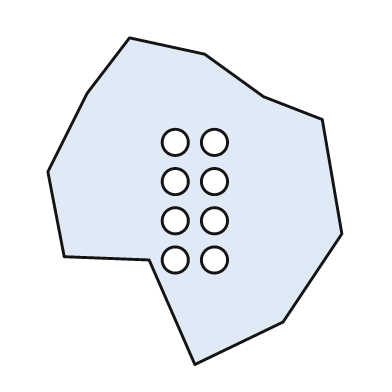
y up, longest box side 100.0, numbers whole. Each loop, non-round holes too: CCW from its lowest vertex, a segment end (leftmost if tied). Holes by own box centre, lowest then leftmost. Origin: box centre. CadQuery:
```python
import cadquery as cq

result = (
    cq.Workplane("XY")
    .moveTo(0.0, -50.0)
    .lineTo(27.0, -37.0)
    .lineTo(45.0, -10.0)
    .lineTo(39.0, 25.0)
    .lineTo(21.0, 32.0)
    .lineTo(3.0, 45.0)
    .lineTo(-20.0, 50.0)
    .lineTo(-33.0, 33.0)
    .lineTo(-45.0, 9.0)
    .lineTo(-40.0, -17.0)
    .lineTo(-14.0, -18.0)
    .close()
    .moveTo(-6.0, -18.0)
    .circle(4.0)
    .moveTo(6.0, -18.0)
    .circle(4.0)
    .moveTo(-6.0, -6.0)
    .circle(4.0)
    .moveTo(6.0, -6.0)
    .circle(4.0)
    .moveTo(-6.0, 6.0)
    .circle(4.0)
    .moveTo(6.0, 6.0)
    .circle(4.0)
    .moveTo(-6.0, 18.0)
    .circle(4.0)
    .moveTo(6.0, 18.0)
    .circle(4.0)
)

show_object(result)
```